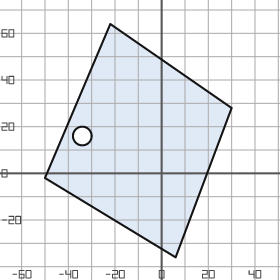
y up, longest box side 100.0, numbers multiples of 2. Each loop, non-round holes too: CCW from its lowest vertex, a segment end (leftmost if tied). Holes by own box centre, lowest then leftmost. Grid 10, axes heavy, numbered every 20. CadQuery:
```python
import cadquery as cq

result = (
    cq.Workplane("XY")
    .moveTo(6.0, -36.0)
    .lineTo(30.0, 28.0)
    .lineTo(-22.0, 64.0)
    .lineTo(-50.0, -2.0)
    .close()
    .moveTo(-34.0, 16.0)
    .circle(4.0)
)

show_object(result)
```